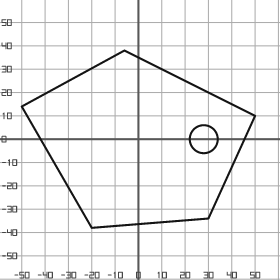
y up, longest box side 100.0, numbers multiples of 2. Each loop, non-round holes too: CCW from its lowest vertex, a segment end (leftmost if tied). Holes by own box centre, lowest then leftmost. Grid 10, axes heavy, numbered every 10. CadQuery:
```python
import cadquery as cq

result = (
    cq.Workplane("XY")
    .moveTo(-20.0, -38.0)
    .lineTo(30.0, -34.0)
    .lineTo(50.0, 10.0)
    .lineTo(-6.0, 38.0)
    .lineTo(-50.0, 14.0)
    .close()
    .moveTo(28.0, 0.0)
    .circle(6.0)
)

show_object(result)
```